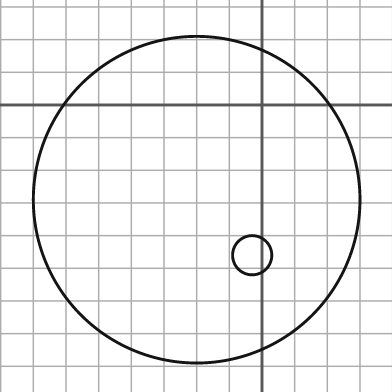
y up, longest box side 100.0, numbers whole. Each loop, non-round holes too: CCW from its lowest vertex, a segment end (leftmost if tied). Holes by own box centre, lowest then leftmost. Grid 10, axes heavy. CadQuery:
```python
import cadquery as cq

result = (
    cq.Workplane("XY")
    .moveTo(-20.0, -29.0)
    .circle(50.0)
    .moveTo(-3.0, -46.0)
    .circle(6.0)
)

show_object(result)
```